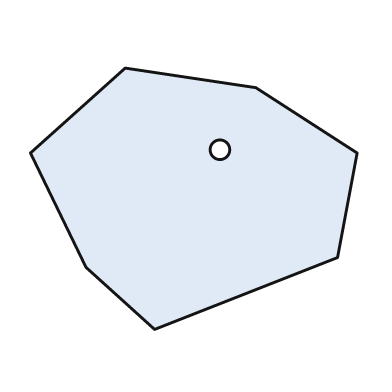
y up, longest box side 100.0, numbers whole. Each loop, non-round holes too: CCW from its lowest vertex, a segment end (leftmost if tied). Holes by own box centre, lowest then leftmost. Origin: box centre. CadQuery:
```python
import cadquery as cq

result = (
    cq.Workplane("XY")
    .moveTo(-12.0, -40.0)
    .lineTo(44.0, -18.0)
    .lineTo(50.0, 14.0)
    .lineTo(19.0, 34.0)
    .lineTo(-21.0, 40.0)
    .lineTo(-50.0, 14.0)
    .lineTo(-33.0, -21.0)
    .close()
    .moveTo(8.0, 15.0)
    .circle(3.0)
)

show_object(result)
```